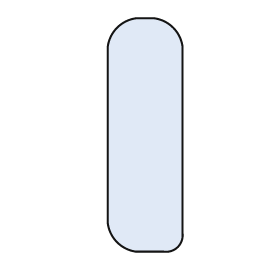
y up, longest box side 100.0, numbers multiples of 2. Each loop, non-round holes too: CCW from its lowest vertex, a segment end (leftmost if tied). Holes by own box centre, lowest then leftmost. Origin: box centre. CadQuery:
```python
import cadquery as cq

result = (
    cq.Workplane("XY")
    .moveTo(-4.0, -50.0)
    .lineTo(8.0, -50.0)
    .threePointArc((14.0, -48.0), (16.0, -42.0))
    .lineTo(16.0, 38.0)
    .threePointArc((12.0, 46.0), (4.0, 50.0))
    .lineTo(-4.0, 50.0)
    .threePointArc((-12.0, 46.0), (-16.0, 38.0))
    .lineTo(-16.0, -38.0)
    .threePointArc((-12.0, -46.0), (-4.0, -50.0))
    .close()
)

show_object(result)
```